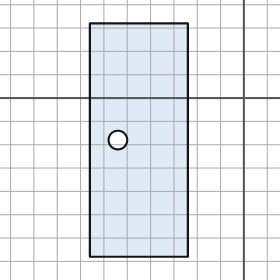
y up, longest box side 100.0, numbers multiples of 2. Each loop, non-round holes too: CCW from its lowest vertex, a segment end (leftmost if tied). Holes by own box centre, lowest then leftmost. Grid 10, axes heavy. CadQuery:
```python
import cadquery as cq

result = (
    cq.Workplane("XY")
    .moveTo(-66.0, -68.0)
    .lineTo(-24.0, -68.0)
    .lineTo(-24.0, 32.0)
    .lineTo(-66.0, 32.0)
    .close()
    .moveTo(-54.0, -18.0)
    .circle(4.0)
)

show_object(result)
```